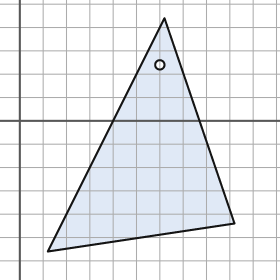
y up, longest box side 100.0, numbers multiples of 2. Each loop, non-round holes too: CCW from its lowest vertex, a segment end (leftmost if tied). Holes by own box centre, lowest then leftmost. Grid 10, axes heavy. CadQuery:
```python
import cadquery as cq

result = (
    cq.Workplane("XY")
    .moveTo(12.0, -56.0)
    .lineTo(92.0, -44.0)
    .lineTo(62.0, 44.0)
    .close()
    .moveTo(60.0, 24.0)
    .circle(2.0)
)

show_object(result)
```